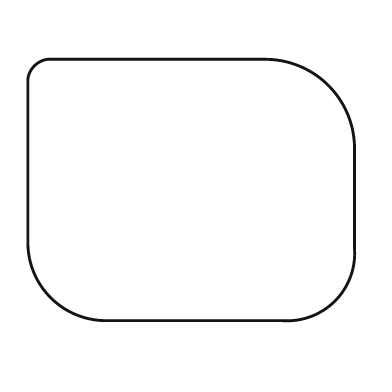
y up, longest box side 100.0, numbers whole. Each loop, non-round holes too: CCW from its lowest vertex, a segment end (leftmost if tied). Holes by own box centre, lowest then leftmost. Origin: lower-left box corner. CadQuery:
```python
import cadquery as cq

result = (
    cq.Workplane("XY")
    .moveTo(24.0, 0.0)
    .lineTo(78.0, 0.0)
    .threePointArc((94.0, 6.0), (100.0, 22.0))
    .lineTo(100.0, 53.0)
    .threePointArc((92.0, 72.0), (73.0, 80.0))
    .lineTo(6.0, 80.0)
    .threePointArc((2.0, 78.0), (0.0, 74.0))
    .lineTo(0.0, 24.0)
    .threePointArc((7.0, 7.0), (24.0, 0.0))
    .close()
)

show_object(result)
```